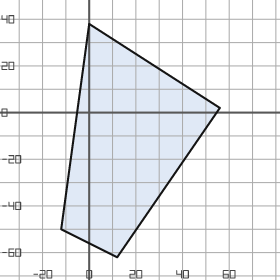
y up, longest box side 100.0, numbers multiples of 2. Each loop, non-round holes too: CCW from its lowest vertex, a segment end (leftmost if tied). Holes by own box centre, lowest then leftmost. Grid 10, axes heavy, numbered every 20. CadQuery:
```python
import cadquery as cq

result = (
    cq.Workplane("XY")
    .moveTo(12.0, -62.0)
    .lineTo(56.0, 2.0)
    .lineTo(0.0, 38.0)
    .lineTo(-12.0, -50.0)
    .close()
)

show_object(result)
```